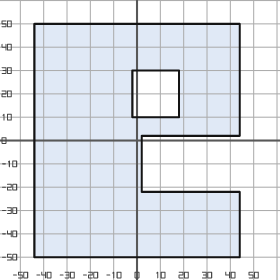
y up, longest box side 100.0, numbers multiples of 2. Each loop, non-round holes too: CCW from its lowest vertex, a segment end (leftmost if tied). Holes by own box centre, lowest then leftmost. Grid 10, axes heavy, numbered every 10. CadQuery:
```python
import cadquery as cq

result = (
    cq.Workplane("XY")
    .moveTo(-44.0, -50.0)
    .lineTo(44.0, -50.0)
    .lineTo(44.0, -22.0)
    .lineTo(2.0, -22.0)
    .lineTo(2.0, 2.0)
    .lineTo(44.0, 2.0)
    .lineTo(44.0, 50.0)
    .lineTo(-44.0, 50.0)
    .close()
    .moveTo(-2.0, 10.0)
    .lineTo(18.0, 10.0)
    .lineTo(18.0, 30.0)
    .lineTo(-2.0, 30.0)
    .close()
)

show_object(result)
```